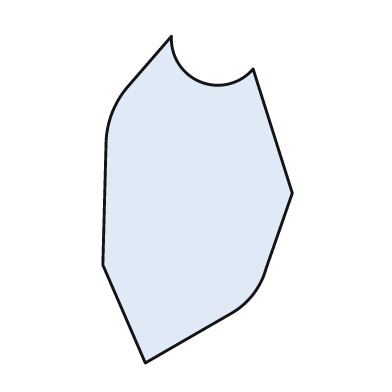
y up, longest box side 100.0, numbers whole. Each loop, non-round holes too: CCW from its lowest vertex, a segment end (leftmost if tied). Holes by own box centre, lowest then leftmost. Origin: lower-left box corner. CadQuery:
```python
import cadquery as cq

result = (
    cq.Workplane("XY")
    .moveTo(13.0, 0.0)
    .lineTo(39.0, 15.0)
    .threePointArc((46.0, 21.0), (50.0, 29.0))
    .lineTo(58.0, 52.0)
    .lineTo(46.0, 90.0)
    .threePointArc((30.0, 86.0), (21.0, 100.0))
    .lineTo(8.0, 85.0)
    .threePointArc((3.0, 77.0), (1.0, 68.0))
    .lineTo(0.0, 30.0)
    .close()
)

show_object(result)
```